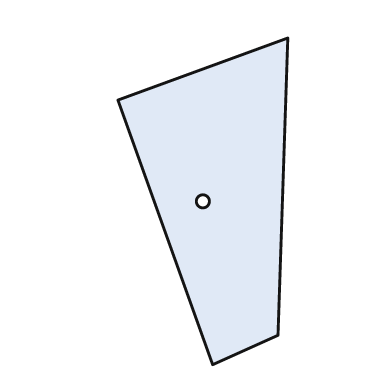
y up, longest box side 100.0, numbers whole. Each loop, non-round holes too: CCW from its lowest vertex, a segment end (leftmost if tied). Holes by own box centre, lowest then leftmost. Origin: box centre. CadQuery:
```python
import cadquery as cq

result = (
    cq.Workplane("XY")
    .moveTo(3.0, -50.0)
    .lineTo(23.0, -41.0)
    .lineTo(26.0, 50.0)
    .lineTo(-26.0, 31.0)
    .close()
    .moveTo(0.0, 0.0)
    .circle(2.0)
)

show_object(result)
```